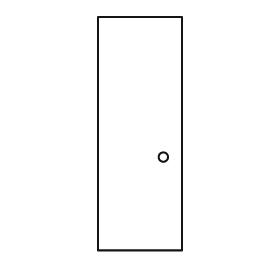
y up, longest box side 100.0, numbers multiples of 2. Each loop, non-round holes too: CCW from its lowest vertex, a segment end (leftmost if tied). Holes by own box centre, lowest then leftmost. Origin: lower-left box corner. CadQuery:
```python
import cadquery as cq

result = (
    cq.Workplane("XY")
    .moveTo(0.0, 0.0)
    .lineTo(36.0, 0.0)
    .lineTo(36.0, 100.0)
    .lineTo(0.0, 100.0)
    .close()
    .moveTo(28.0, 40.0)
    .circle(2.0)
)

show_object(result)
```